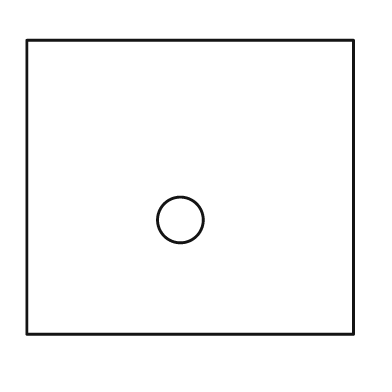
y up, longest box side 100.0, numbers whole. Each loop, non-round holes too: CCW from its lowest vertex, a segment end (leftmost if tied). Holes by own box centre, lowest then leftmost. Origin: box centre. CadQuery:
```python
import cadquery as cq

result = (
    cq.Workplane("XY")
    .moveTo(-50.0, -45.0)
    .lineTo(50.0, -45.0)
    .lineTo(50.0, 45.0)
    .lineTo(-50.0, 45.0)
    .close()
    .moveTo(-3.0, -10.0)
    .circle(7.0)
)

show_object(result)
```